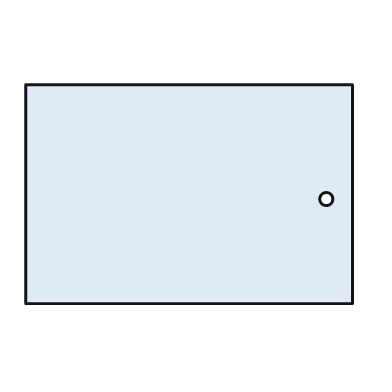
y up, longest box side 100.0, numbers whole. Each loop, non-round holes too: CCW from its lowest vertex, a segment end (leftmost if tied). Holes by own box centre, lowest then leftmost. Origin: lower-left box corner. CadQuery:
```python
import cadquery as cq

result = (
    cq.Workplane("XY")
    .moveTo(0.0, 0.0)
    .lineTo(100.0, 0.0)
    .lineTo(100.0, 67.0)
    .lineTo(0.0, 67.0)
    .close()
    .moveTo(92.0, 32.0)
    .circle(2.0)
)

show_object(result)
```